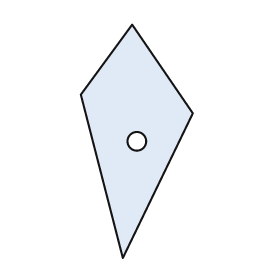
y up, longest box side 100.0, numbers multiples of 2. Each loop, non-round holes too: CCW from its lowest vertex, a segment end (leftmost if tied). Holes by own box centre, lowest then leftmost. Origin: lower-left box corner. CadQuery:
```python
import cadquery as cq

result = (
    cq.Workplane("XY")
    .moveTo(18.0, 0.0)
    .lineTo(48.0, 62.0)
    .lineTo(22.0, 100.0)
    .lineTo(0.0, 70.0)
    .close()
    .moveTo(24.0, 50.0)
    .circle(4.0)
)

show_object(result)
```